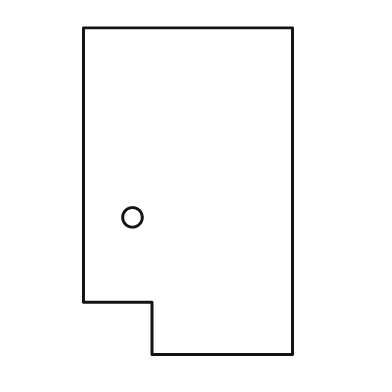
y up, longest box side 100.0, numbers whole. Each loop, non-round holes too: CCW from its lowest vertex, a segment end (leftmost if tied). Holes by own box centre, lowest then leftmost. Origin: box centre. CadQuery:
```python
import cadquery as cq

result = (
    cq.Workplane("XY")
    .moveTo(-11.0, -50.0)
    .lineTo(32.0, -50.0)
    .lineTo(32.0, 50.0)
    .lineTo(-32.0, 50.0)
    .lineTo(-32.0, -34.0)
    .lineTo(-11.0, -34.0)
    .close()
    .moveTo(-17.0, -8.0)
    .circle(3.0)
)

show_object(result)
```